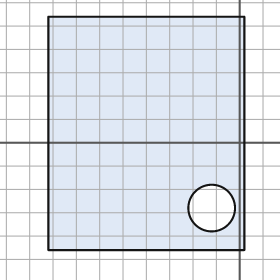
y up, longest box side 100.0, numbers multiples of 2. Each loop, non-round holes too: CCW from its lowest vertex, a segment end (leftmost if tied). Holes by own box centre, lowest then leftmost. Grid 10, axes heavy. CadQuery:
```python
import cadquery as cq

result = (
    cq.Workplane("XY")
    .moveTo(-82.0, -46.0)
    .lineTo(2.0, -46.0)
    .lineTo(2.0, 54.0)
    .lineTo(-82.0, 54.0)
    .close()
    .moveTo(-12.0, -28.0)
    .circle(10.0)
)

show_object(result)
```